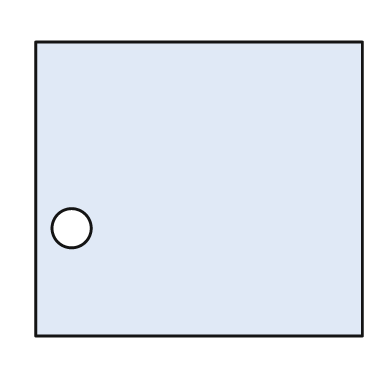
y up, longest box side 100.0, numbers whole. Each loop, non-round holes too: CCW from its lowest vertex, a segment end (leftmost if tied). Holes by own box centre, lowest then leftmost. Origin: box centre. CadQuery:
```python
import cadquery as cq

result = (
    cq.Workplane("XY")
    .moveTo(-50.0, -45.0)
    .lineTo(50.0, -45.0)
    .lineTo(50.0, 45.0)
    .lineTo(-50.0, 45.0)
    .close()
    .moveTo(-39.0, -12.0)
    .circle(6.0)
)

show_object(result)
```